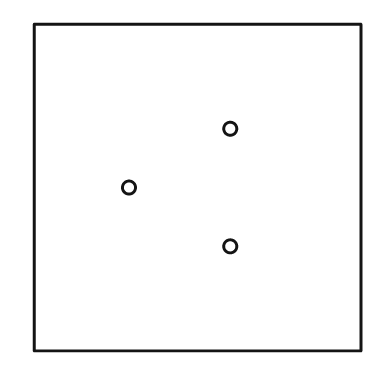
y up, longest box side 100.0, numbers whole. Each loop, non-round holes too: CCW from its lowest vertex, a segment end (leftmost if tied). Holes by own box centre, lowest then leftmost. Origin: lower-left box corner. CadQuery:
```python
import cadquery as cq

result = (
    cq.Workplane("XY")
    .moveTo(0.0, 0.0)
    .lineTo(100.0, 0.0)
    .lineTo(100.0, 100.0)
    .lineTo(0.0, 100.0)
    .close()
    .moveTo(60.0, 32.0)
    .circle(2.0)
    .moveTo(29.0, 50.0)
    .circle(2.0)
    .moveTo(60.0, 68.0)
    .circle(2.0)
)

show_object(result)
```